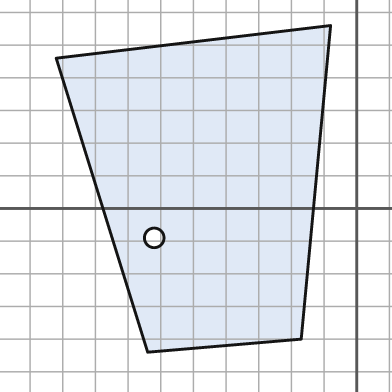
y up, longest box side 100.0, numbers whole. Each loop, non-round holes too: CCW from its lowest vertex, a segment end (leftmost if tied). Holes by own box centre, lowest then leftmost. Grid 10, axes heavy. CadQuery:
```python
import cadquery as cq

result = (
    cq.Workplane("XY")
    .moveTo(-64.0, -44.0)
    .lineTo(-17.0, -40.0)
    .lineTo(-8.0, 56.0)
    .lineTo(-92.0, 46.0)
    .close()
    .moveTo(-62.0, -9.0)
    .circle(3.0)
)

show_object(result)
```